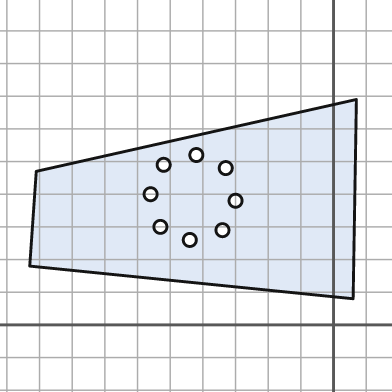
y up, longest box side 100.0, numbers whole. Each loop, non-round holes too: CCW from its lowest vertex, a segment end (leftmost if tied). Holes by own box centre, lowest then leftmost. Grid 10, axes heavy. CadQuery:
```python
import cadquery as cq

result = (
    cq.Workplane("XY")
    .moveTo(6.0, 8.0)
    .lineTo(7.0, 69.0)
    .lineTo(-91.0, 47.0)
    .lineTo(-93.0, 18.0)
    .close()
    .moveTo(-44.0, 26.0)
    .circle(2.0)
    .moveTo(-34.0, 29.0)
    .circle(2.0)
    .moveTo(-53.0, 30.0)
    .circle(2.0)
    .moveTo(-30.0, 38.0)
    .circle(2.0)
    .moveTo(-56.0, 40.0)
    .circle(2.0)
    .moveTo(-33.0, 48.0)
    .circle(2.0)
    .moveTo(-52.0, 49.0)
    .circle(2.0)
    .moveTo(-42.0, 52.0)
    .circle(2.0)
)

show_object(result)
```